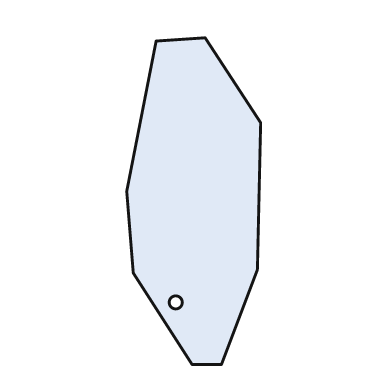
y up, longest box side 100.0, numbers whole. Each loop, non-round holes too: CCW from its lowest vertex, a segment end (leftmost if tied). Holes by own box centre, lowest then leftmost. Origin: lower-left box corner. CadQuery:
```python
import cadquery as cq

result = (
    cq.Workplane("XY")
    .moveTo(20.0, 0.0)
    .lineTo(29.0, 0.0)
    .lineTo(40.0, 29.0)
    .lineTo(41.0, 74.0)
    .lineTo(24.0, 100.0)
    .lineTo(9.0, 99.0)
    .lineTo(0.0, 53.0)
    .lineTo(2.0, 28.0)
    .close()
    .moveTo(15.0, 19.0)
    .circle(2.0)
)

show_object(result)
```